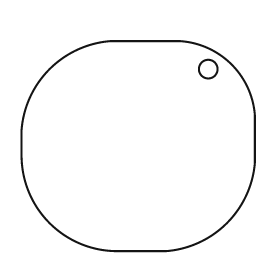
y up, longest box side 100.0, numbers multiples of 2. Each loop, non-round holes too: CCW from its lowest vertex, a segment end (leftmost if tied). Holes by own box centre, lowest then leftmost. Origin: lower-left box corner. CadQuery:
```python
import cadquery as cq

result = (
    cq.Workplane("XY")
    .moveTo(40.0, 0.0)
    .lineTo(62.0, 0.0)
    .threePointArc((88.0, 12.0), (100.0, 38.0))
    .lineTo(100.0, 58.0)
    .threePointArc((90.0, 80.0), (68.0, 90.0))
    .lineTo(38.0, 90.0)
    .threePointArc((12.0, 78.0), (0.0, 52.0))
    .lineTo(0.0, 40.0)
    .threePointArc((12.0, 12.0), (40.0, 0.0))
    .close()
    .moveTo(80.0, 78.0)
    .circle(4.0)
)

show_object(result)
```